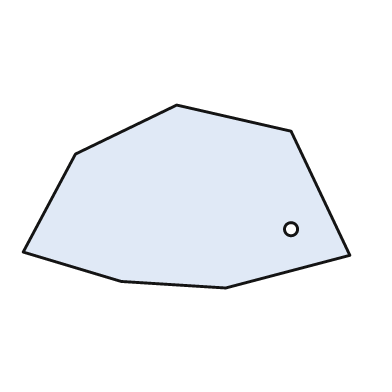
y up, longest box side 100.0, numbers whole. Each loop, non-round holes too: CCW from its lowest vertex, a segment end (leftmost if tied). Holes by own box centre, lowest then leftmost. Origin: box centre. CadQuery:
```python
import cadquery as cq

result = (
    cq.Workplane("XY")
    .moveTo(12.0, -28.0)
    .lineTo(50.0, -18.0)
    .lineTo(32.0, 20.0)
    .lineTo(-3.0, 28.0)
    .lineTo(-34.0, 13.0)
    .lineTo(-50.0, -17.0)
    .lineTo(-20.0, -26.0)
    .close()
    .moveTo(32.0, -10.0)
    .circle(2.0)
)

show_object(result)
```